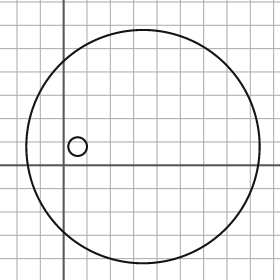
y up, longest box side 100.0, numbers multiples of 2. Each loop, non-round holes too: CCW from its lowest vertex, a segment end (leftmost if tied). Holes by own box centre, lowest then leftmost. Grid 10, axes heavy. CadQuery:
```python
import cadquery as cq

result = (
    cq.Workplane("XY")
    .moveTo(34.0, 8.0)
    .circle(50.0)
    .moveTo(6.0, 8.0)
    .circle(4.0)
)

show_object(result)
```